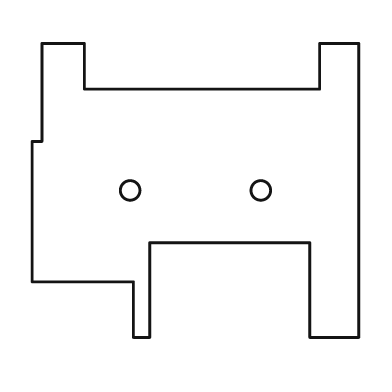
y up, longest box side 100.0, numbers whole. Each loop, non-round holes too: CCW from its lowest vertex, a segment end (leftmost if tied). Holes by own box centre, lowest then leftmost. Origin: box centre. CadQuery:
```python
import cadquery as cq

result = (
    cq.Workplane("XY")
    .moveTo(-19.0, -45.0)
    .lineTo(-14.0, -45.0)
    .lineTo(-14.0, -16.0)
    .lineTo(35.0, -16.0)
    .lineTo(35.0, -45.0)
    .lineTo(50.0, -45.0)
    .lineTo(50.0, 45.0)
    .lineTo(38.0, 45.0)
    .lineTo(38.0, 31.0)
    .lineTo(-34.0, 31.0)
    .lineTo(-34.0, 45.0)
    .lineTo(-47.0, 45.0)
    .lineTo(-47.0, 15.0)
    .lineTo(-50.0, 15.0)
    .lineTo(-50.0, -28.0)
    .lineTo(-19.0, -28.0)
    .close()
    .moveTo(-20.0, 0.0)
    .circle(3.0)
    .moveTo(20.0, 0.0)
    .circle(3.0)
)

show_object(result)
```